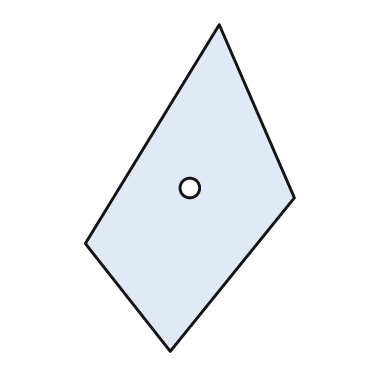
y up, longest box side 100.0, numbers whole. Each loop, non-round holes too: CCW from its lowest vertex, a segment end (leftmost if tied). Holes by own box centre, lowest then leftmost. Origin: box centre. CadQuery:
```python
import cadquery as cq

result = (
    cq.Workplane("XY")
    .moveTo(-6.0, -50.0)
    .lineTo(32.0, -3.0)
    .lineTo(9.0, 50.0)
    .lineTo(-32.0, -17.0)
    .close()
    .moveTo(0.0, 0.0)
    .circle(3.0)
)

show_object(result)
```